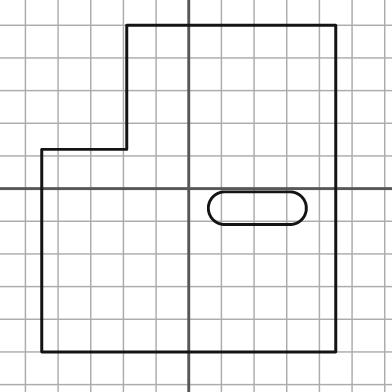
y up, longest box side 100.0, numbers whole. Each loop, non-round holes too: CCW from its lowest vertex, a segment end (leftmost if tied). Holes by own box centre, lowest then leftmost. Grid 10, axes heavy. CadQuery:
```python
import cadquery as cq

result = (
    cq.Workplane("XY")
    .moveTo(-45.0, -50.0)
    .lineTo(45.0, -50.0)
    .lineTo(45.0, 50.0)
    .lineTo(-19.0, 50.0)
    .lineTo(-19.0, 12.0)
    .lineTo(-45.0, 12.0)
    .close()
    .moveTo(11.0, -11.0)
    .lineTo(31.0, -11.0)
    .threePointArc((36.0, -6.0), (31.0, -1.0))
    .lineTo(11.0, -1.0)
    .threePointArc((6.0, -6.0), (11.0, -11.0))
    .close()
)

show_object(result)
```